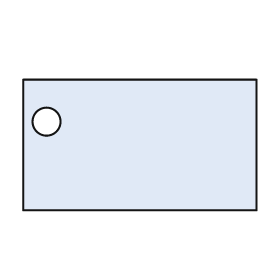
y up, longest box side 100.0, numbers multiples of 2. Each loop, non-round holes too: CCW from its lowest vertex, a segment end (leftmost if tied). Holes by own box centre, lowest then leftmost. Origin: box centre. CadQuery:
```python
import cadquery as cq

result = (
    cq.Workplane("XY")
    .moveTo(-50.0, -28.0)
    .lineTo(50.0, -28.0)
    .lineTo(50.0, 28.0)
    .lineTo(-50.0, 28.0)
    .close()
    .moveTo(-40.0, 10.0)
    .circle(6.0)
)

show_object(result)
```